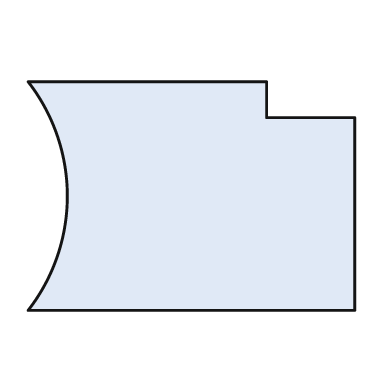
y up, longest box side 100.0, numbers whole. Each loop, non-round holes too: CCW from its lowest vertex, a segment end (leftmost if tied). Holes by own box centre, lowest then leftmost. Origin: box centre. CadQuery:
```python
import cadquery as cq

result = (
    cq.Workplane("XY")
    .moveTo(-50.0, -35.0)
    .lineTo(50.0, -35.0)
    .lineTo(50.0, 24.0)
    .lineTo(23.0, 24.0)
    .lineTo(23.0, 35.0)
    .lineTo(-50.0, 35.0)
    .threePointArc((-38.0, 0.0), (-50.0, -35.0))
    .close()
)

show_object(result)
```